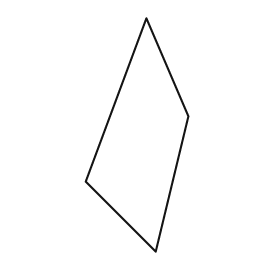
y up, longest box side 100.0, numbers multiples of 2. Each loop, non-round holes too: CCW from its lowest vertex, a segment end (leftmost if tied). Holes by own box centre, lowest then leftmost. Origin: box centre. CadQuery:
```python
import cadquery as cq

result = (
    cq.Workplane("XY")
    .moveTo(8.0, -50.0)
    .lineTo(22.0, 8.0)
    .lineTo(4.0, 50.0)
    .lineTo(-22.0, -20.0)
    .close()
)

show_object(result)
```